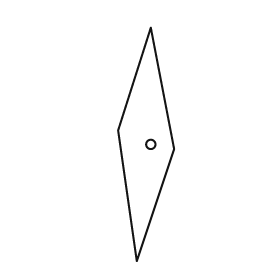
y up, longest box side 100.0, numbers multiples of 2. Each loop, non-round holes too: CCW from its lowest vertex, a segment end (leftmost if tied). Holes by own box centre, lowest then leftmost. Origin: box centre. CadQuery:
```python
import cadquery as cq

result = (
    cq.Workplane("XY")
    .moveTo(-4.0, -50.0)
    .lineTo(12.0, -2.0)
    .lineTo(2.0, 50.0)
    .lineTo(-12.0, 6.0)
    .close()
    .moveTo(2.0, 0.0)
    .circle(2.0)
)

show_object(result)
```